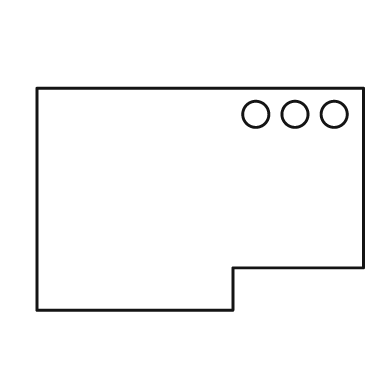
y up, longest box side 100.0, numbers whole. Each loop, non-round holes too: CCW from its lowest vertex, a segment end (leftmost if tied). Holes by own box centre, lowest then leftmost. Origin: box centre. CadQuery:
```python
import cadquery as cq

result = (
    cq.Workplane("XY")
    .moveTo(-50.0, -34.0)
    .lineTo(10.0, -34.0)
    .lineTo(10.0, -21.0)
    .lineTo(50.0, -21.0)
    .lineTo(50.0, 34.0)
    .lineTo(-50.0, 34.0)
    .close()
    .moveTo(17.0, 26.0)
    .circle(4.0)
    .moveTo(29.0, 26.0)
    .circle(4.0)
    .moveTo(41.0, 26.0)
    .circle(4.0)
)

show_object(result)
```